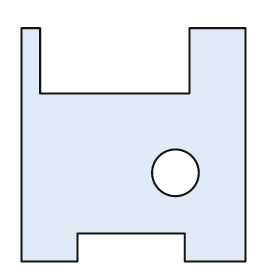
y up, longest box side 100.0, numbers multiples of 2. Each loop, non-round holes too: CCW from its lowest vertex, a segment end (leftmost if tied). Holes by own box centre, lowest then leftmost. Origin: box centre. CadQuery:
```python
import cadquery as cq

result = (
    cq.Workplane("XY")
    .moveTo(-48.0, -50.0)
    .lineTo(-24.0, -50.0)
    .lineTo(-24.0, -38.0)
    .lineTo(22.0, -38.0)
    .lineTo(22.0, -50.0)
    .lineTo(48.0, -50.0)
    .lineTo(48.0, 50.0)
    .lineTo(24.0, 50.0)
    .lineTo(24.0, 22.0)
    .lineTo(-40.0, 22.0)
    .lineTo(-40.0, 50.0)
    .lineTo(-48.0, 50.0)
    .close()
    .moveTo(18.0, -12.0)
    .circle(10.0)
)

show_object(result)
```